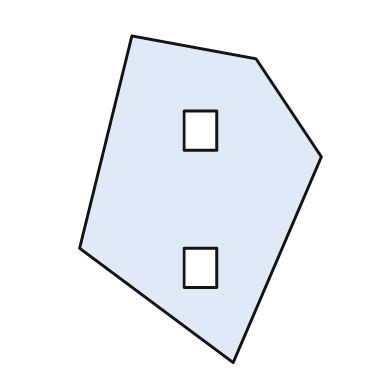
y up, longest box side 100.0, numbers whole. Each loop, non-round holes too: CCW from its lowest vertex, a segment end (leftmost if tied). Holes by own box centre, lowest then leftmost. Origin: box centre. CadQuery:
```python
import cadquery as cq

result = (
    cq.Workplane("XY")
    .moveTo(10.0, -50.0)
    .lineTo(37.0, 13.0)
    .lineTo(17.0, 43.0)
    .lineTo(-21.0, 50.0)
    .lineTo(-37.0, -15.0)
    .close()
    .moveTo(-5.0, -27.0)
    .lineTo(5.0, -27.0)
    .lineTo(5.0, -15.0)
    .lineTo(-5.0, -15.0)
    .close()
    .moveTo(-5.0, 15.0)
    .lineTo(5.0, 15.0)
    .lineTo(5.0, 27.0)
    .lineTo(-5.0, 27.0)
    .close()
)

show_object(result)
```